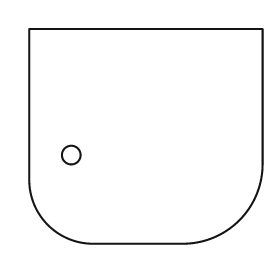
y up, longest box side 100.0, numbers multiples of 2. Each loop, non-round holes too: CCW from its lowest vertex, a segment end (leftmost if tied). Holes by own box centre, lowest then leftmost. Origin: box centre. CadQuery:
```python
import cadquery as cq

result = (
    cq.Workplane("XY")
    .moveTo(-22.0, -46.0)
    .lineTo(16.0, -46.0)
    .threePointArc((40.0, -36.0), (50.0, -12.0))
    .lineTo(50.0, 46.0)
    .lineTo(-50.0, 46.0)
    .lineTo(-50.0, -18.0)
    .threePointArc((-42.0, -38.0), (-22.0, -46.0))
    .close()
    .moveTo(-32.0, -8.0)
    .circle(4.0)
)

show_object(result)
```